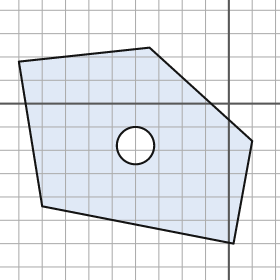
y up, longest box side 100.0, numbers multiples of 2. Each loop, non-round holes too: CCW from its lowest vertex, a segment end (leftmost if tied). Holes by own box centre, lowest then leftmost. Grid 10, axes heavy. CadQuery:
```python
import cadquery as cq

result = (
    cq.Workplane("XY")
    .moveTo(2.0, -60.0)
    .lineTo(10.0, -16.0)
    .lineTo(-34.0, 24.0)
    .lineTo(-90.0, 18.0)
    .lineTo(-80.0, -44.0)
    .close()
    .moveTo(-40.0, -18.0)
    .circle(8.0)
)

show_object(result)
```